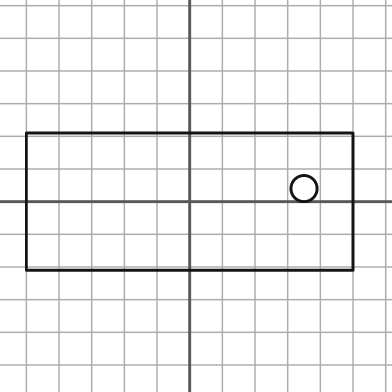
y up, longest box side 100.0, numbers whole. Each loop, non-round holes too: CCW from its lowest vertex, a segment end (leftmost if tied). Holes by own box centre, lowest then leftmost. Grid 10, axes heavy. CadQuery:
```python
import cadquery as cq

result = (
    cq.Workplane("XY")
    .moveTo(-50.0, -21.0)
    .lineTo(50.0, -21.0)
    .lineTo(50.0, 21.0)
    .lineTo(-50.0, 21.0)
    .close()
    .moveTo(35.0, 4.0)
    .circle(4.0)
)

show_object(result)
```